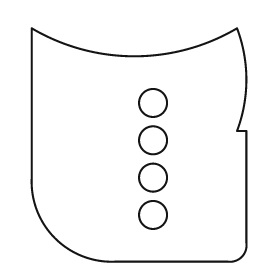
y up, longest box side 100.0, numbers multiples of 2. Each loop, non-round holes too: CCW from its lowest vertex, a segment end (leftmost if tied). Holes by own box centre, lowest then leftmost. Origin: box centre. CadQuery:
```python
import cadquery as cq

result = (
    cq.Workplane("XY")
    .moveTo(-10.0, -50.0)
    .lineTo(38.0, -50.0)
    .threePointArc((44.0, -48.0), (46.0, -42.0))
    .lineTo(46.0, 6.0)
    .lineTo(42.0, 6.0)
    .threePointArc((46.0, 28.0), (42.0, 50.0))
    .threePointArc((-2.0, 38.0), (-46.0, 50.0))
    .lineTo(-46.0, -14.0)
    .threePointArc((-36.0, -40.0), (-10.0, -50.0))
    .close()
    .moveTo(6.0, -30.0)
    .circle(6.0)
    .moveTo(6.0, -14.0)
    .circle(6.0)
    .moveTo(6.0, 2.0)
    .circle(6.0)
    .moveTo(6.0, 18.0)
    .circle(6.0)
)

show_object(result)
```